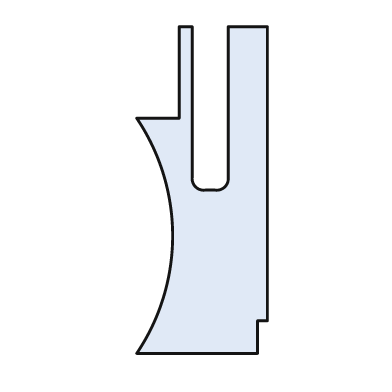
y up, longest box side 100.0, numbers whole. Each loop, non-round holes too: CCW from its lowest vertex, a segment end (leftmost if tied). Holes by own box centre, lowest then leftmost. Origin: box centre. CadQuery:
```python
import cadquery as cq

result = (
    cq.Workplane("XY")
    .moveTo(-20.0, -50.0)
    .lineTo(17.0, -50.0)
    .lineTo(17.0, -40.0)
    .lineTo(20.0, -40.0)
    .lineTo(20.0, 50.0)
    .lineTo(8.0, 50.0)
    .lineTo(8.0, 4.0)
    .threePointArc((7.0, 1.0), (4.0, 0.0))
    .lineTo(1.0, 0.0)
    .threePointArc((-2.0, 1.0), (-3.0, 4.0))
    .lineTo(-3.0, 50.0)
    .lineTo(-7.0, 50.0)
    .lineTo(-7.0, 22.0)
    .lineTo(-20.0, 22.0)
    .threePointArc((-9.0, -14.0), (-20.0, -50.0))
    .close()
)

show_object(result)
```